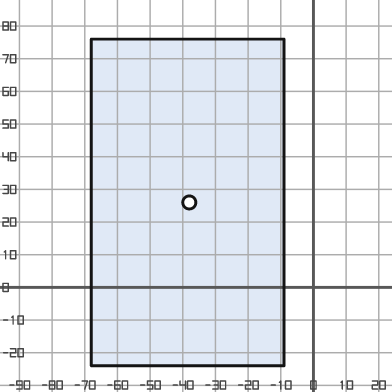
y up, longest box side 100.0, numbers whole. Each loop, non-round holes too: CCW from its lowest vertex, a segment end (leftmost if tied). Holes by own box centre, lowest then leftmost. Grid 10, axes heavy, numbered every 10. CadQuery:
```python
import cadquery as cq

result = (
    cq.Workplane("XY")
    .moveTo(-68.0, -24.0)
    .lineTo(-9.0, -24.0)
    .lineTo(-9.0, 76.0)
    .lineTo(-68.0, 76.0)
    .close()
    .moveTo(-38.0, 26.0)
    .circle(2.0)
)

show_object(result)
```